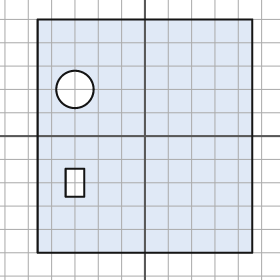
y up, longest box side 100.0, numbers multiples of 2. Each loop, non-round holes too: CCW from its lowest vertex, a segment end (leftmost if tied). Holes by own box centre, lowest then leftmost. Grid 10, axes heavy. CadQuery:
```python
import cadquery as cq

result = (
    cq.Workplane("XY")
    .moveTo(-46.0, -50.0)
    .lineTo(46.0, -50.0)
    .lineTo(46.0, 50.0)
    .lineTo(-46.0, 50.0)
    .close()
    .moveTo(-34.0, -26.0)
    .lineTo(-26.0, -26.0)
    .lineTo(-26.0, -14.0)
    .lineTo(-34.0, -14.0)
    .close()
    .moveTo(-30.0, 20.0)
    .circle(8.0)
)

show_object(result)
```